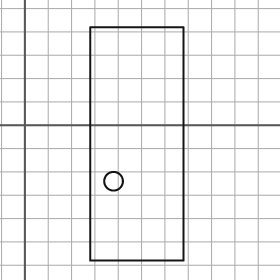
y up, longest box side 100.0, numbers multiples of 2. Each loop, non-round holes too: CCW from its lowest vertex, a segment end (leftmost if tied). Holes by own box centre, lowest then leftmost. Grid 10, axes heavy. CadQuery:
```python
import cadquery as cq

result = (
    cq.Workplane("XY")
    .moveTo(28.0, -58.0)
    .lineTo(68.0, -58.0)
    .lineTo(68.0, 42.0)
    .lineTo(28.0, 42.0)
    .close()
    .moveTo(38.0, -24.0)
    .circle(4.0)
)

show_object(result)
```